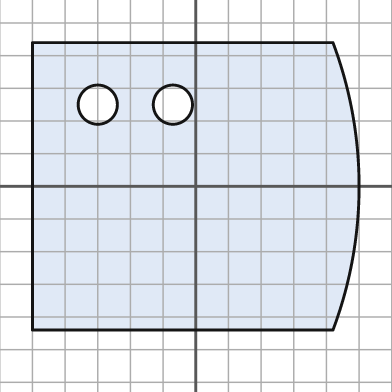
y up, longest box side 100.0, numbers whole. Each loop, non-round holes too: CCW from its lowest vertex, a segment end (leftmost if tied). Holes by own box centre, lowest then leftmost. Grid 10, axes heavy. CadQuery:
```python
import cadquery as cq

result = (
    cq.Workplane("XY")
    .moveTo(-50.0, -44.0)
    .lineTo(42.0, -44.0)
    .threePointArc((50.0, 0.0), (42.0, 44.0))
    .lineTo(-50.0, 44.0)
    .close()
    .moveTo(-30.0, 25.0)
    .circle(6.0)
    .moveTo(-7.0, 25.0)
    .circle(6.0)
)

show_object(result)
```